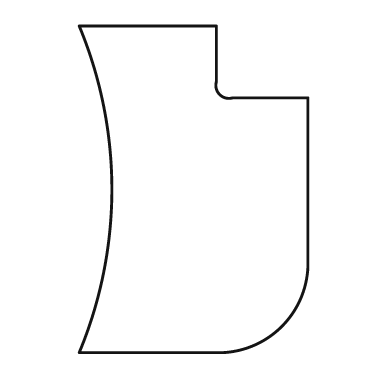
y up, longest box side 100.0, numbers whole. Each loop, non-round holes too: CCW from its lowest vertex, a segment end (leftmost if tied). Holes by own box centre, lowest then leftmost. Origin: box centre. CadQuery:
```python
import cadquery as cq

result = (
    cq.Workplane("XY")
    .moveTo(-35.0, -50.0)
    .lineTo(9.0, -50.0)
    .threePointArc((27.0, -42.0), (35.0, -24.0))
    .lineTo(35.0, 28.0)
    .lineTo(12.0, 28.0)
    .threePointArc((8.0, 29.0), (7.0, 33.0))
    .lineTo(7.0, 50.0)
    .lineTo(-35.0, 50.0)
    .threePointArc((-25.0, 0.0), (-35.0, -50.0))
    .close()
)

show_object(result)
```